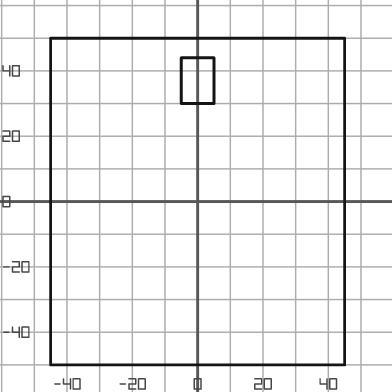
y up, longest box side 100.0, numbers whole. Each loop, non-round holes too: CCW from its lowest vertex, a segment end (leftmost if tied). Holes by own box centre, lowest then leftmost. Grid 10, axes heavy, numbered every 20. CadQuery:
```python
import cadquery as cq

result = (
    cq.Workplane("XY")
    .moveTo(-45.0, -50.0)
    .lineTo(45.0, -50.0)
    .lineTo(45.0, 50.0)
    .lineTo(-45.0, 50.0)
    .close()
    .moveTo(-5.0, 30.0)
    .lineTo(5.0, 30.0)
    .lineTo(5.0, 44.0)
    .lineTo(-5.0, 44.0)
    .close()
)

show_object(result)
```